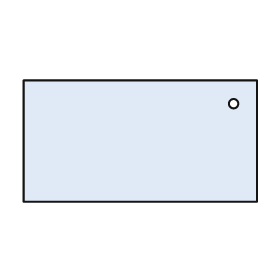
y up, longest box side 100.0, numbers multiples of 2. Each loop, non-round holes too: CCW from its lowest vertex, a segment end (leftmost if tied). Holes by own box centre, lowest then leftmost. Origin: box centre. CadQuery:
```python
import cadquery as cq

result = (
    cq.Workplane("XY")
    .moveTo(-50.0, -26.0)
    .lineTo(50.0, -26.0)
    .lineTo(50.0, 26.0)
    .lineTo(-50.0, 26.0)
    .close()
    .moveTo(40.0, 16.0)
    .circle(2.0)
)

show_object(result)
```